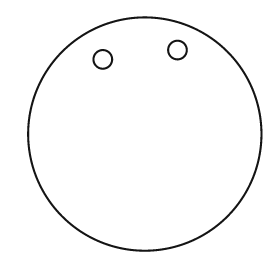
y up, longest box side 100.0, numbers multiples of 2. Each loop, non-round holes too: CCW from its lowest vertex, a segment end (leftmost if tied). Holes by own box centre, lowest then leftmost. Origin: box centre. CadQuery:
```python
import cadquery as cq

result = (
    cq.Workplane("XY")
    .moveTo(0.0, 0.0)
    .circle(50.0)
    .moveTo(-18.0, 32.0)
    .circle(4.0)
    .moveTo(14.0, 36.0)
    .circle(4.0)
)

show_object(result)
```